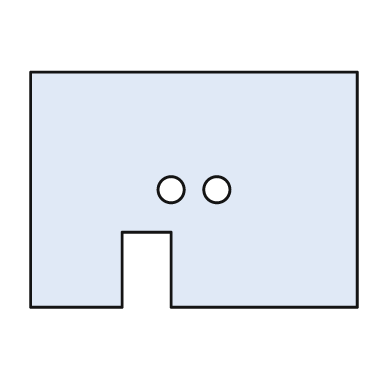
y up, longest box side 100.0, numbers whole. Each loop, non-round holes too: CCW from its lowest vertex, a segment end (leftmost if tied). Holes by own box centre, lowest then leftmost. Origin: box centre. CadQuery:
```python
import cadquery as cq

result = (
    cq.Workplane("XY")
    .moveTo(-50.0, -36.0)
    .lineTo(-22.0, -36.0)
    .lineTo(-22.0, -13.0)
    .lineTo(-7.0, -13.0)
    .lineTo(-7.0, -36.0)
    .lineTo(50.0, -36.0)
    .lineTo(50.0, 36.0)
    .lineTo(-50.0, 36.0)
    .close()
    .moveTo(-7.0, 0.0)
    .circle(4.0)
    .moveTo(7.0, 0.0)
    .circle(4.0)
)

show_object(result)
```